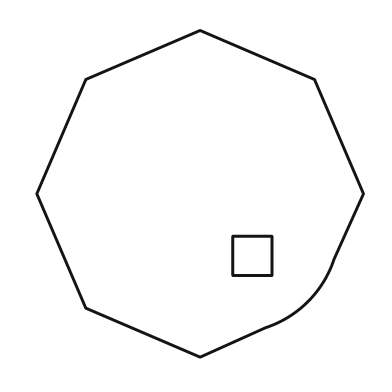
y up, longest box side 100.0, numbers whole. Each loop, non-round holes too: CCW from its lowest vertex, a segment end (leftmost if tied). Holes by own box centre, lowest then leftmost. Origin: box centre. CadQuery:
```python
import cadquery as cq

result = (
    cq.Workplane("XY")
    .moveTo(0.0, -50.0)
    .lineTo(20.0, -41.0)
    .threePointArc((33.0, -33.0), (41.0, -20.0))
    .lineTo(50.0, 0.0)
    .lineTo(35.0, 35.0)
    .lineTo(0.0, 50.0)
    .lineTo(-35.0, 35.0)
    .lineTo(-50.0, 0.0)
    .lineTo(-35.0, -35.0)
    .close()
    .moveTo(10.0, -25.0)
    .lineTo(22.0, -25.0)
    .lineTo(22.0, -13.0)
    .lineTo(10.0, -13.0)
    .close()
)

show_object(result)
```